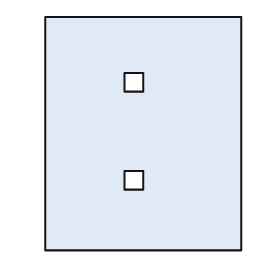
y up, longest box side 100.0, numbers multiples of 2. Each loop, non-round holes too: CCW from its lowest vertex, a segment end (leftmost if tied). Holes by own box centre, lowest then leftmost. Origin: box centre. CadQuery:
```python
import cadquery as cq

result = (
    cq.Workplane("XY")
    .moveTo(-42.0, -50.0)
    .lineTo(42.0, -50.0)
    .lineTo(42.0, 50.0)
    .lineTo(-42.0, 50.0)
    .close()
    .moveTo(-8.0, -24.0)
    .lineTo(0.0, -24.0)
    .lineTo(0.0, -16.0)
    .lineTo(-8.0, -16.0)
    .close()
    .moveTo(-8.0, 18.0)
    .lineTo(0.0, 18.0)
    .lineTo(0.0, 26.0)
    .lineTo(-8.0, 26.0)
    .close()
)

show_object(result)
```